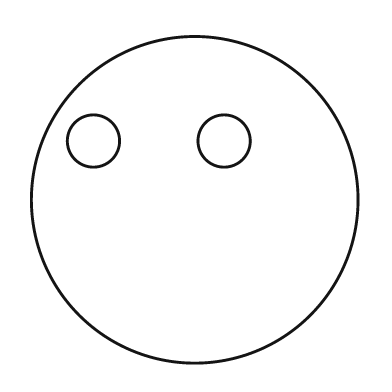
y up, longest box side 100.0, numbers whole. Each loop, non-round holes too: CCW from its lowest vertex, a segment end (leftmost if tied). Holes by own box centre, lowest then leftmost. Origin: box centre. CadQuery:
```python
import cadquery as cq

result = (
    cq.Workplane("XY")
    .moveTo(0.0, 0.0)
    .circle(50.0)
    .moveTo(-31.0, 18.0)
    .circle(8.0)
    .moveTo(9.0, 18.0)
    .circle(8.0)
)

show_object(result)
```